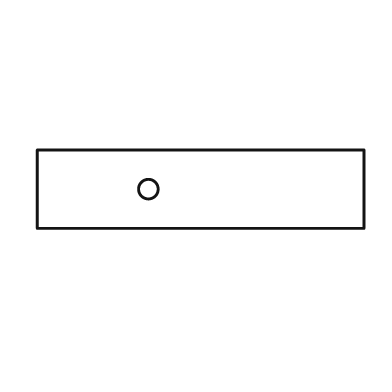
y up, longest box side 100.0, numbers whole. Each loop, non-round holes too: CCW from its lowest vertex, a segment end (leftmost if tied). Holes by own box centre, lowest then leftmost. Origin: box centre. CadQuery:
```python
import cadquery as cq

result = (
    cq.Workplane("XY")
    .moveTo(-50.0, -12.0)
    .lineTo(50.0, -12.0)
    .lineTo(50.0, 12.0)
    .lineTo(-50.0, 12.0)
    .close()
    .moveTo(-16.0, 0.0)
    .circle(3.0)
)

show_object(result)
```